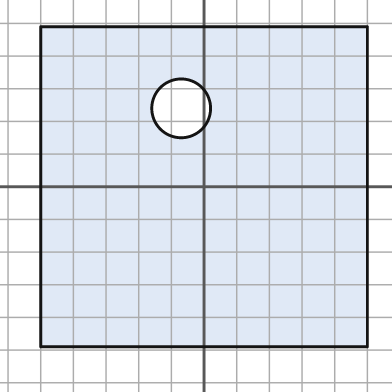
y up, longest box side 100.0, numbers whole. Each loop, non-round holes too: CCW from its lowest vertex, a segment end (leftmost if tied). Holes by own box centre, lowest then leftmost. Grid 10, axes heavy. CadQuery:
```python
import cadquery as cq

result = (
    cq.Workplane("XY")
    .moveTo(-50.0, -49.0)
    .lineTo(50.0, -49.0)
    .lineTo(50.0, 49.0)
    .lineTo(-50.0, 49.0)
    .close()
    .moveTo(-7.0, 24.0)
    .circle(9.0)
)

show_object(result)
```